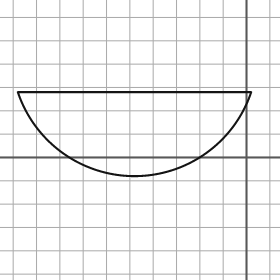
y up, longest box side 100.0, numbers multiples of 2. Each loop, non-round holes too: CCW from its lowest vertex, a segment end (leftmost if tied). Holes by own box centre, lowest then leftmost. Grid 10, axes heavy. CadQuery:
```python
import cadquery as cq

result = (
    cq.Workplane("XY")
    .moveTo(-98.0, 28.0)
    .threePointArc((-48.0, -8.0), (2.0, 28.0))
    .close()
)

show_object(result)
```